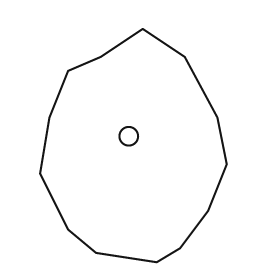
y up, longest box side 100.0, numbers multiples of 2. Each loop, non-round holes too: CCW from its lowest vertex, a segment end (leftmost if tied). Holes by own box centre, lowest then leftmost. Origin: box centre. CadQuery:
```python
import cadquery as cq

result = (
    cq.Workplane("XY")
    .moveTo(10.0, -50.0)
    .lineTo(20.0, -44.0)
    .lineTo(32.0, -28.0)
    .lineTo(40.0, -8.0)
    .lineTo(36.0, 12.0)
    .lineTo(22.0, 38.0)
    .lineTo(4.0, 50.0)
    .lineTo(-14.0, 38.0)
    .lineTo(-28.0, 32.0)
    .lineTo(-36.0, 12.0)
    .lineTo(-40.0, -12.0)
    .lineTo(-28.0, -36.0)
    .lineTo(-16.0, -46.0)
    .close()
    .moveTo(-2.0, 4.0)
    .circle(4.0)
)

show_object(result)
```